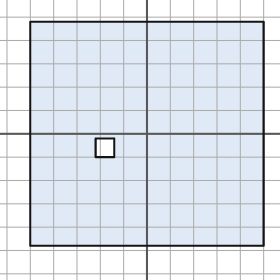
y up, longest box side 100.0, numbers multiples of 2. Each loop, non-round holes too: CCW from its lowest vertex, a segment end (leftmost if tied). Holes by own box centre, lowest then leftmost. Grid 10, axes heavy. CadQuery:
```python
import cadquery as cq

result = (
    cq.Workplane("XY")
    .moveTo(-50.0, -48.0)
    .lineTo(50.0, -48.0)
    .lineTo(50.0, 48.0)
    .lineTo(-50.0, 48.0)
    .close()
    .moveTo(-22.0, -10.0)
    .lineTo(-14.0, -10.0)
    .lineTo(-14.0, -2.0)
    .lineTo(-22.0, -2.0)
    .close()
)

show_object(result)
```